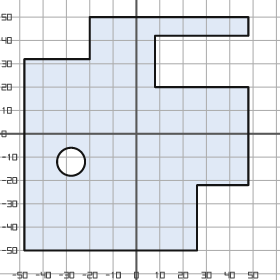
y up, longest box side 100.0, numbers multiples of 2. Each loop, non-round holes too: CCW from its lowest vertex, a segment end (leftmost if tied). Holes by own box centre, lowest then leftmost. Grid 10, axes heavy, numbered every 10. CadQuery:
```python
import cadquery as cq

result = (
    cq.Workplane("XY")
    .moveTo(-48.0, -50.0)
    .lineTo(26.0, -50.0)
    .lineTo(26.0, -22.0)
    .lineTo(48.0, -22.0)
    .lineTo(48.0, 20.0)
    .lineTo(8.0, 20.0)
    .lineTo(8.0, 42.0)
    .lineTo(48.0, 42.0)
    .lineTo(48.0, 50.0)
    .lineTo(-20.0, 50.0)
    .lineTo(-20.0, 32.0)
    .lineTo(-48.0, 32.0)
    .close()
    .moveTo(-28.0, -12.0)
    .circle(6.0)
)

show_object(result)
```